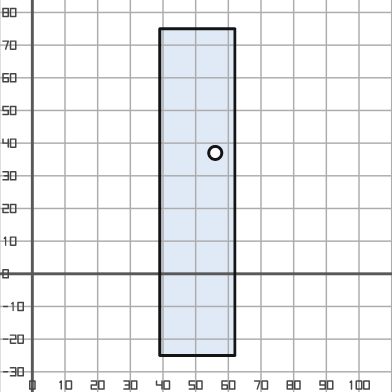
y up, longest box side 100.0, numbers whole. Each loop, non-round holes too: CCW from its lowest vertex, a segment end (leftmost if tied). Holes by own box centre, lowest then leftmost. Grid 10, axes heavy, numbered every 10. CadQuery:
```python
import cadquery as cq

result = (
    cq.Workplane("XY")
    .moveTo(39.0, -25.0)
    .lineTo(62.0, -25.0)
    .lineTo(62.0, 75.0)
    .lineTo(39.0, 75.0)
    .close()
    .moveTo(56.0, 37.0)
    .circle(2.0)
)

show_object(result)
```